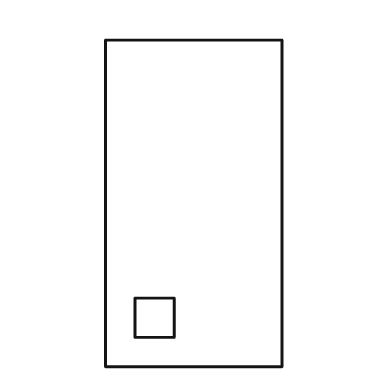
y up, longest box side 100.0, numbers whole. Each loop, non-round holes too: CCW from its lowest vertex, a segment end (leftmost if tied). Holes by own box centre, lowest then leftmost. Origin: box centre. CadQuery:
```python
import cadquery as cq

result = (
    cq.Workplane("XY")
    .moveTo(-27.0, -50.0)
    .lineTo(27.0, -50.0)
    .lineTo(27.0, 50.0)
    .lineTo(-27.0, 50.0)
    .close()
    .moveTo(-18.0, -41.0)
    .lineTo(-6.0, -41.0)
    .lineTo(-6.0, -29.0)
    .lineTo(-18.0, -29.0)
    .close()
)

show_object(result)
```